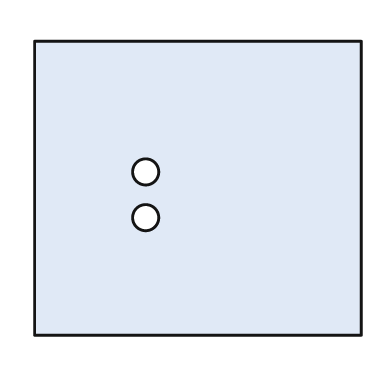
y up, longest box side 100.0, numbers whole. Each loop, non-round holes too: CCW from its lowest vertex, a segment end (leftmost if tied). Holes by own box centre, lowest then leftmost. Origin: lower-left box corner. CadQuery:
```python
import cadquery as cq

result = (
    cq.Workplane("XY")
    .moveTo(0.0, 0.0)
    .lineTo(100.0, 0.0)
    .lineTo(100.0, 90.0)
    .lineTo(0.0, 90.0)
    .close()
    .moveTo(34.0, 36.0)
    .circle(4.0)
    .moveTo(34.0, 50.0)
    .circle(4.0)
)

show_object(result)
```